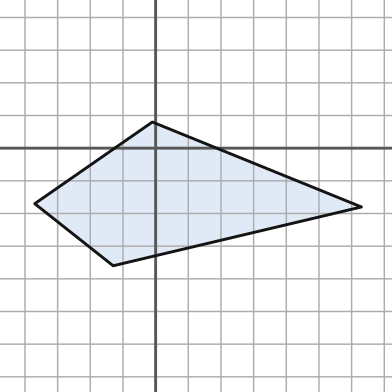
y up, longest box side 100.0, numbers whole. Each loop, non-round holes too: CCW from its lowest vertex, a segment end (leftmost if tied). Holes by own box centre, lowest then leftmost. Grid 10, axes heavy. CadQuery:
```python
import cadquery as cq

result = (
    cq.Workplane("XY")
    .moveTo(-13.0, -36.0)
    .lineTo(63.0, -18.0)
    .lineTo(-1.0, 8.0)
    .lineTo(-37.0, -17.0)
    .close()
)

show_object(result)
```